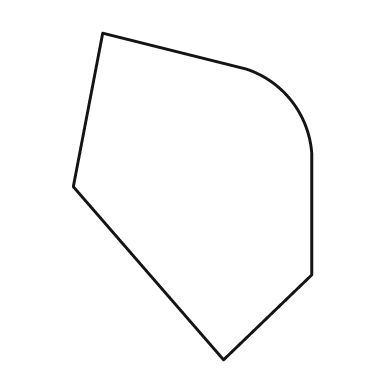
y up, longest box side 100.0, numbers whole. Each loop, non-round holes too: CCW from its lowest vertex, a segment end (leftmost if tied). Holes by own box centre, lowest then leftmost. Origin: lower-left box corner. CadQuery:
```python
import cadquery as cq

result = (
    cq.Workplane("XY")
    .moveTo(46.0, 0.0)
    .lineTo(73.0, 26.0)
    .lineTo(73.0, 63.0)
    .threePointArc((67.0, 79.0), (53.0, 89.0))
    .lineTo(9.0, 100.0)
    .lineTo(0.0, 53.0)
    .close()
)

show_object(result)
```